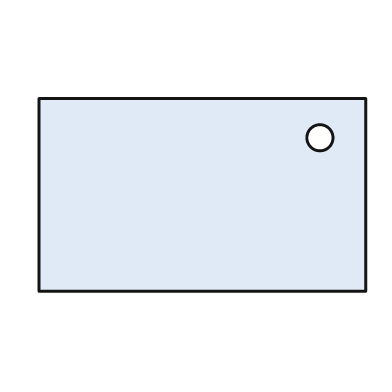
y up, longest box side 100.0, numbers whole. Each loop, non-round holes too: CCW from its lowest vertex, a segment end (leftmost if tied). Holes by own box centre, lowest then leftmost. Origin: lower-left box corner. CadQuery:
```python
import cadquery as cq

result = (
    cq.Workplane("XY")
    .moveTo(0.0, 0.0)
    .lineTo(100.0, 0.0)
    .lineTo(100.0, 59.0)
    .lineTo(0.0, 59.0)
    .close()
    .moveTo(86.0, 47.0)
    .circle(4.0)
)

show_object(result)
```